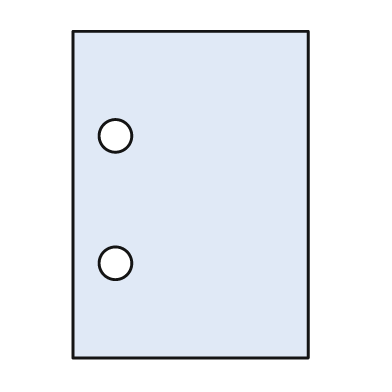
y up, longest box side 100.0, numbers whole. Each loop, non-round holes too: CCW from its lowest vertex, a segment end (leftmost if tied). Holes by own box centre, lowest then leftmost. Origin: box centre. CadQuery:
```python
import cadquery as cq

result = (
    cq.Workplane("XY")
    .moveTo(-36.0, -50.0)
    .lineTo(36.0, -50.0)
    .lineTo(36.0, 50.0)
    .lineTo(-36.0, 50.0)
    .close()
    .moveTo(-23.0, -21.0)
    .circle(5.0)
    .moveTo(-23.0, 18.0)
    .circle(5.0)
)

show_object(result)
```